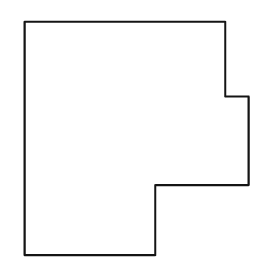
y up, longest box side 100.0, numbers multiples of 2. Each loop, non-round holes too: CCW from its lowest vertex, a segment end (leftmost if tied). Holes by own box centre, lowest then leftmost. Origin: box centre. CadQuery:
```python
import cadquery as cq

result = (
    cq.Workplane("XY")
    .moveTo(-48.0, -50.0)
    .lineTo(8.0, -50.0)
    .lineTo(8.0, -20.0)
    .lineTo(48.0, -20.0)
    .lineTo(48.0, 18.0)
    .lineTo(38.0, 18.0)
    .lineTo(38.0, 50.0)
    .lineTo(-48.0, 50.0)
    .close()
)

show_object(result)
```